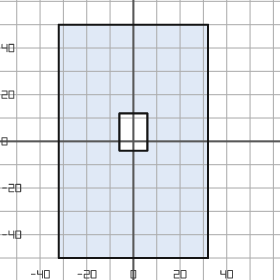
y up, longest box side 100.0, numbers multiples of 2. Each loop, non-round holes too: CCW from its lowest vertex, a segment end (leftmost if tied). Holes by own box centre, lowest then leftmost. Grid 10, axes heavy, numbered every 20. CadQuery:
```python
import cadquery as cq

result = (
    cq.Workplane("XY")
    .moveTo(-32.0, -50.0)
    .lineTo(32.0, -50.0)
    .lineTo(32.0, 50.0)
    .lineTo(-32.0, 50.0)
    .close()
    .moveTo(-6.0, -4.0)
    .lineTo(6.0, -4.0)
    .lineTo(6.0, 12.0)
    .lineTo(-6.0, 12.0)
    .close()
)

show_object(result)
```